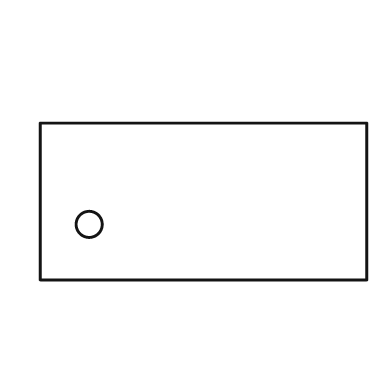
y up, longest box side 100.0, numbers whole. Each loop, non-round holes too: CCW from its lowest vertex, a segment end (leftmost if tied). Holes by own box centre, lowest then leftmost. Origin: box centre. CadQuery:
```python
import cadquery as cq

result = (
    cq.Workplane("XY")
    .moveTo(-50.0, -24.0)
    .lineTo(50.0, -24.0)
    .lineTo(50.0, 24.0)
    .lineTo(-50.0, 24.0)
    .close()
    .moveTo(-35.0, -7.0)
    .circle(4.0)
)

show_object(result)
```